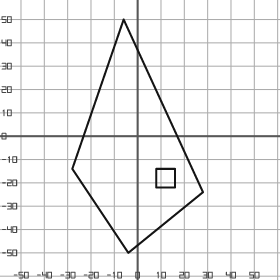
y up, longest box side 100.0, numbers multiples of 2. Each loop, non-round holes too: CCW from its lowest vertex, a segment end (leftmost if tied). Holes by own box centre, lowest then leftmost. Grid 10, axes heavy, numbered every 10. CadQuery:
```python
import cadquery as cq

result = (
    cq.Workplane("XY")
    .moveTo(-4.0, -50.0)
    .lineTo(28.0, -24.0)
    .lineTo(-6.0, 50.0)
    .lineTo(-28.0, -14.0)
    .close()
    .moveTo(8.0, -22.0)
    .lineTo(16.0, -22.0)
    .lineTo(16.0, -14.0)
    .lineTo(8.0, -14.0)
    .close()
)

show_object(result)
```